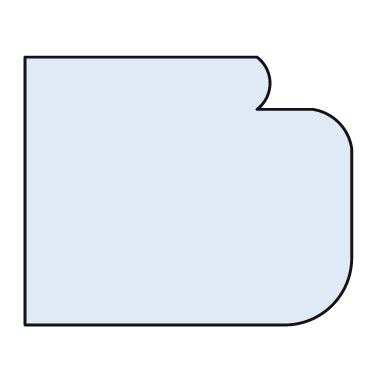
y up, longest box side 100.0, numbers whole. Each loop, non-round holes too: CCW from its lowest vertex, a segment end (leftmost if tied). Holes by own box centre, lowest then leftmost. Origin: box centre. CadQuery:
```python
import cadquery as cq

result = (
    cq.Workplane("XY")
    .moveTo(-50.0, -41.0)
    .lineTo(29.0, -41.0)
    .threePointArc((44.0, -35.0), (50.0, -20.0))
    .lineTo(50.0, 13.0)
    .threePointArc((46.0, 21.0), (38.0, 25.0))
    .lineTo(21.0, 25.0)
    .threePointArc((25.0, 33.0), (21.0, 41.0))
    .lineTo(-50.0, 41.0)
    .close()
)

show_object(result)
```